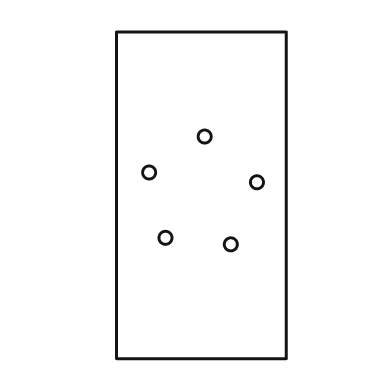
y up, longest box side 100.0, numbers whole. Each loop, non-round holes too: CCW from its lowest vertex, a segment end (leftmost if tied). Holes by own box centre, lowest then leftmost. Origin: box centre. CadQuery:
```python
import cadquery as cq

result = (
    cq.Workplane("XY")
    .moveTo(-26.0, -50.0)
    .lineTo(26.0, -50.0)
    .lineTo(26.0, 50.0)
    .lineTo(-26.0, 50.0)
    .close()
    .moveTo(9.0, -15.0)
    .circle(2.0)
    .moveTo(-11.0, -13.0)
    .circle(2.0)
    .moveTo(17.0, 4.0)
    .circle(2.0)
    .moveTo(-16.0, 7.0)
    .circle(2.0)
    .moveTo(1.0, 18.0)
    .circle(2.0)
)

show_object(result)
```